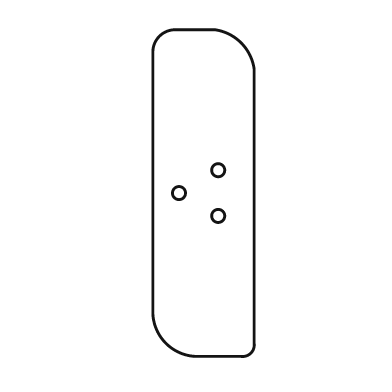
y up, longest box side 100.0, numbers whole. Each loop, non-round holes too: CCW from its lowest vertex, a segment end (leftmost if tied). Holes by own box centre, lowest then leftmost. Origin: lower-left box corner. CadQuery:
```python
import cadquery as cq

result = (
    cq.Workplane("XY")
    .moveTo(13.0, 0.0)
    .lineTo(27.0, 0.0)
    .threePointArc((30.0, 1.0), (31.0, 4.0))
    .lineTo(31.0, 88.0)
    .threePointArc((27.0, 96.0), (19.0, 100.0))
    .lineTo(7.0, 100.0)
    .threePointArc((2.0, 98.0), (0.0, 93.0))
    .lineTo(0.0, 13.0)
    .threePointArc((4.0, 4.0), (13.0, 0.0))
    .close()
    .moveTo(20.0, 43.0)
    .circle(2.0)
    .moveTo(8.0, 50.0)
    .circle(2.0)
    .moveTo(20.0, 57.0)
    .circle(2.0)
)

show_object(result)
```